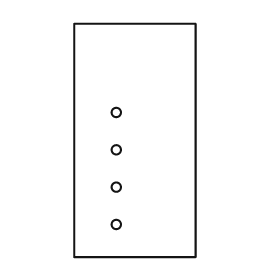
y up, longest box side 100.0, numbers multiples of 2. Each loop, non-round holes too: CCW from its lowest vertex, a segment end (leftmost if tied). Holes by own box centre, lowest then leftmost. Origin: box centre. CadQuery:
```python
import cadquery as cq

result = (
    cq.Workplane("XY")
    .moveTo(-26.0, -50.0)
    .lineTo(26.0, -50.0)
    .lineTo(26.0, 50.0)
    .lineTo(-26.0, 50.0)
    .close()
    .moveTo(-8.0, -36.0)
    .circle(2.0)
    .moveTo(-8.0, -20.0)
    .circle(2.0)
    .moveTo(-8.0, -4.0)
    .circle(2.0)
    .moveTo(-8.0, 12.0)
    .circle(2.0)
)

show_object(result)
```